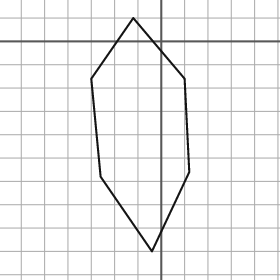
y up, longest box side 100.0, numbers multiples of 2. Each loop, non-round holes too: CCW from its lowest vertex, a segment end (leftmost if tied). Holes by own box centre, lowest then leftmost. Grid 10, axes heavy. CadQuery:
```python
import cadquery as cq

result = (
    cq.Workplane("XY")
    .moveTo(-4.0, -90.0)
    .lineTo(12.0, -56.0)
    .lineTo(10.0, -16.0)
    .lineTo(-12.0, 10.0)
    .lineTo(-30.0, -16.0)
    .lineTo(-26.0, -58.0)
    .close()
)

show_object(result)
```